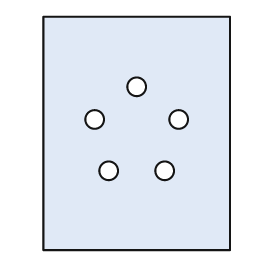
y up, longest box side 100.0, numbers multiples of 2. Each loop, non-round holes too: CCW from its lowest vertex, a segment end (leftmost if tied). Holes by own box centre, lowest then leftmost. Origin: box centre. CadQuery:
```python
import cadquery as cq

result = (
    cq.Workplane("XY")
    .moveTo(-40.0, -50.0)
    .lineTo(40.0, -50.0)
    .lineTo(40.0, 50.0)
    .lineTo(-40.0, 50.0)
    .close()
    .moveTo(-12.0, -16.0)
    .circle(4.0)
    .moveTo(12.0, -16.0)
    .circle(4.0)
    .moveTo(-18.0, 6.0)
    .circle(4.0)
    .moveTo(18.0, 6.0)
    .circle(4.0)
    .moveTo(0.0, 20.0)
    .circle(4.0)
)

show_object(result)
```